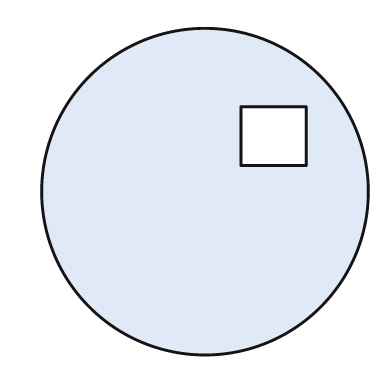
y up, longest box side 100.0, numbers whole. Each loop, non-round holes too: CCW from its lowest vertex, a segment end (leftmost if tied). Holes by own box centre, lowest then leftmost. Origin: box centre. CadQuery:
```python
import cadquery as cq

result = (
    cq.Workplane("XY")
    .moveTo(0.0, 0.0)
    .circle(50.0)
    .moveTo(11.0, 8.0)
    .lineTo(31.0, 8.0)
    .lineTo(31.0, 26.0)
    .lineTo(11.0, 26.0)
    .close()
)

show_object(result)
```